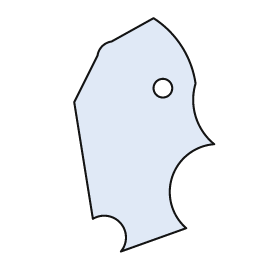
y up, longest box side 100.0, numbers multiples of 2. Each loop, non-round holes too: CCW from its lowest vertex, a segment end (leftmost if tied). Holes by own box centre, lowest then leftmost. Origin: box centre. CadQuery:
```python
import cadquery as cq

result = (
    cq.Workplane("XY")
    .moveTo(-10.0, -50.0)
    .lineTo(18.0, -40.0)
    .threePointArc((12.0, -18.0), (30.0, -4.0))
    .threePointArc((22.0, 8.0), (22.0, 22.0))
    .threePointArc((16.0, 38.0), (4.0, 50.0))
    .lineTo(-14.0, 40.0)
    .threePointArc((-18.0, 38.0), (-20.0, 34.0))
    .lineTo(-30.0, 14.0)
    .lineTo(-22.0, -36.0)
    .threePointArc((-10.0, -38.0), (-10.0, -50.0))
    .close()
    .moveTo(8.0, 20.0)
    .circle(4.0)
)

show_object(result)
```